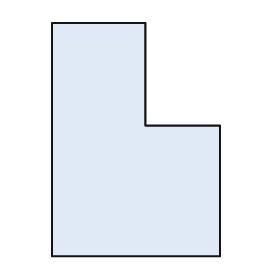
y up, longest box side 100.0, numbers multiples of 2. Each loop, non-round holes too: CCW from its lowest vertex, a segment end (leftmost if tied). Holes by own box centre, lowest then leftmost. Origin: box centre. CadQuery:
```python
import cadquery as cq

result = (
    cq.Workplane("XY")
    .moveTo(-36.0, -50.0)
    .lineTo(36.0, -50.0)
    .lineTo(36.0, 6.0)
    .lineTo(4.0, 6.0)
    .lineTo(4.0, 50.0)
    .lineTo(-36.0, 50.0)
    .close()
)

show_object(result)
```